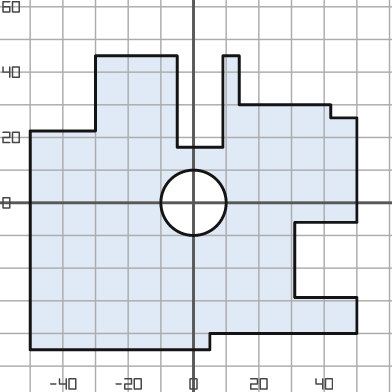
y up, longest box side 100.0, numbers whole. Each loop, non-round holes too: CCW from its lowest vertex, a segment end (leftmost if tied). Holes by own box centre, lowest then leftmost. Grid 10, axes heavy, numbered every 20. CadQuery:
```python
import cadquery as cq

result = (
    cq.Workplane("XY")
    .moveTo(-50.0, -45.0)
    .lineTo(5.0, -45.0)
    .lineTo(5.0, -40.0)
    .lineTo(50.0, -40.0)
    .lineTo(50.0, -29.0)
    .lineTo(31.0, -29.0)
    .lineTo(31.0, -6.0)
    .lineTo(50.0, -6.0)
    .lineTo(50.0, 26.0)
    .lineTo(42.0, 26.0)
    .lineTo(42.0, 30.0)
    .lineTo(14.0, 30.0)
    .lineTo(14.0, 45.0)
    .lineTo(9.0, 45.0)
    .lineTo(9.0, 17.0)
    .lineTo(-5.0, 17.0)
    .lineTo(-5.0, 45.0)
    .lineTo(-30.0, 45.0)
    .lineTo(-30.0, 22.0)
    .lineTo(-50.0, 22.0)
    .close()
    .moveTo(0.0, 0.0)
    .circle(10.0)
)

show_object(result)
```